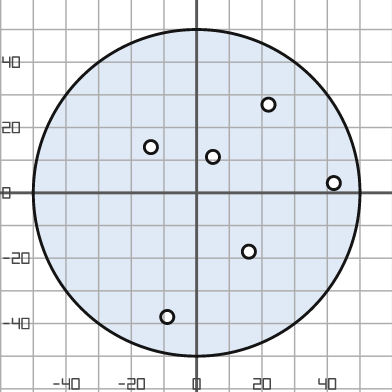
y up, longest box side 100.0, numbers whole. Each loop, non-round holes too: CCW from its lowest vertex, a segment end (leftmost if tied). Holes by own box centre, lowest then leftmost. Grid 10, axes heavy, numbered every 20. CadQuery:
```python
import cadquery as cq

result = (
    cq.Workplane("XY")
    .moveTo(0.0, 0.0)
    .circle(50.0)
    .moveTo(-9.0, -38.0)
    .circle(2.0)
    .moveTo(16.0, -18.0)
    .circle(2.0)
    .moveTo(42.0, 3.0)
    .circle(2.0)
    .moveTo(5.0, 11.0)
    .circle(2.0)
    .moveTo(-14.0, 14.0)
    .circle(2.0)
    .moveTo(22.0, 27.0)
    .circle(2.0)
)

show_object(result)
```